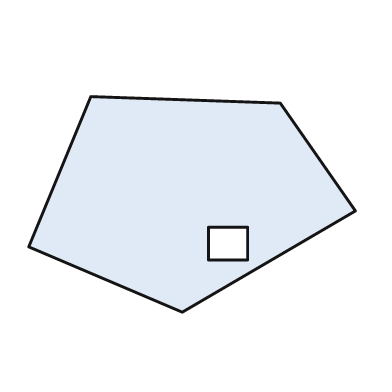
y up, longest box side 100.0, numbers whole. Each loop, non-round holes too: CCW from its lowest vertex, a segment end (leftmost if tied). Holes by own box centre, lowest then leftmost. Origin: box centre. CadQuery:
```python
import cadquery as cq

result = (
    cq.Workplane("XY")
    .moveTo(-3.0, -33.0)
    .lineTo(50.0, -2.0)
    .lineTo(27.0, 31.0)
    .lineTo(-31.0, 33.0)
    .lineTo(-50.0, -13.0)
    .close()
    .moveTo(5.0, -17.0)
    .lineTo(17.0, -17.0)
    .lineTo(17.0, -7.0)
    .lineTo(5.0, -7.0)
    .close()
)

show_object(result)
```